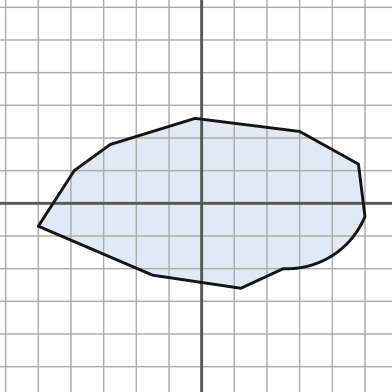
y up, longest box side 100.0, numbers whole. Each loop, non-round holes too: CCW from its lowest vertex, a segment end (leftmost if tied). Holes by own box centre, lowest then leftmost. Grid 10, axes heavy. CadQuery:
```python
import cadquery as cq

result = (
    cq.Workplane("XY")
    .moveTo(12.0, -26.0)
    .lineTo(25.0, -20.0)
    .threePointArc((40.0, -16.0), (50.0, -4.0))
    .lineTo(48.0, 12.0)
    .lineTo(30.0, 22.0)
    .lineTo(-2.0, 26.0)
    .lineTo(-28.0, 18.0)
    .lineTo(-39.0, 10.0)
    .lineTo(-50.0, -7.0)
    .lineTo(-15.0, -22.0)
    .close()
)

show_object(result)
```